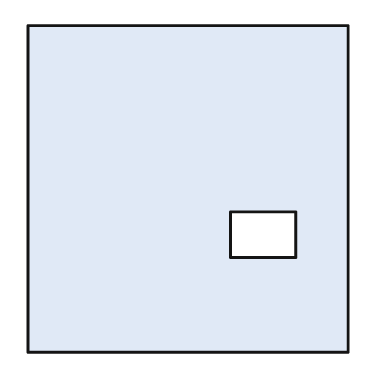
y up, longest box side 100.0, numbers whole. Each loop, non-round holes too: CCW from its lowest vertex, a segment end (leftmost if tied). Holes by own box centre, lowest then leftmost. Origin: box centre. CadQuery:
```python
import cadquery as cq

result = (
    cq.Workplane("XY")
    .moveTo(-49.0, -50.0)
    .lineTo(49.0, -50.0)
    .lineTo(49.0, 50.0)
    .lineTo(-49.0, 50.0)
    .close()
    .moveTo(13.0, -21.0)
    .lineTo(33.0, -21.0)
    .lineTo(33.0, -7.0)
    .lineTo(13.0, -7.0)
    .close()
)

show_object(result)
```